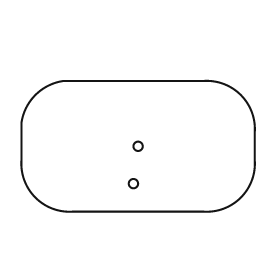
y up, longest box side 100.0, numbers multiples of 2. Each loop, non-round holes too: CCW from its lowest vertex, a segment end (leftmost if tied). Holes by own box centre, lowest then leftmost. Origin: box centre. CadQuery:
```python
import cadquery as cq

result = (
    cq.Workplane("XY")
    .moveTo(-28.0, -28.0)
    .lineTo(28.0, -28.0)
    .threePointArc((44.0, -22.0), (50.0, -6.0))
    .lineTo(50.0, 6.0)
    .threePointArc((44.0, 22.0), (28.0, 28.0))
    .lineTo(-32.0, 28.0)
    .threePointArc((-44.0, 22.0), (-50.0, 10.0))
    .lineTo(-50.0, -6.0)
    .threePointArc((-44.0, -22.0), (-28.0, -28.0))
    .close()
    .moveTo(-2.0, -16.0)
    .circle(2.0)
    .moveTo(0.0, 0.0)
    .circle(2.0)
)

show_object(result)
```